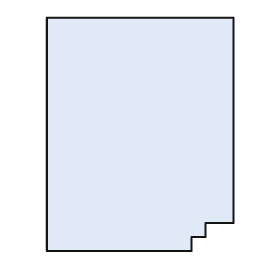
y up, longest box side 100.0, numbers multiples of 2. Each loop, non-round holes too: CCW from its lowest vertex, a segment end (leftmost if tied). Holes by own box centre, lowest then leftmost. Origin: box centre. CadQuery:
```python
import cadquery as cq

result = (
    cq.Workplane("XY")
    .moveTo(-40.0, -50.0)
    .lineTo(22.0, -50.0)
    .lineTo(22.0, -44.0)
    .lineTo(28.0, -44.0)
    .lineTo(28.0, -38.0)
    .lineTo(40.0, -38.0)
    .lineTo(40.0, 50.0)
    .lineTo(-40.0, 50.0)
    .close()
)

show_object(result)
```